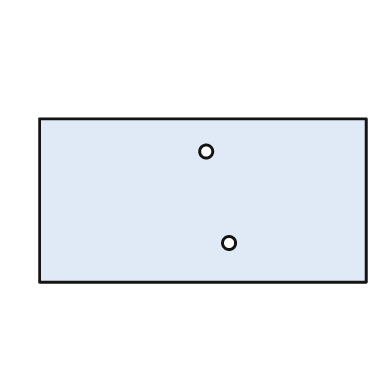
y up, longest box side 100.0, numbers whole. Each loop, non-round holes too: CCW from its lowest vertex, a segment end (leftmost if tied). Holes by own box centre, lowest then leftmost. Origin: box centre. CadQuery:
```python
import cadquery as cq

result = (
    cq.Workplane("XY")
    .moveTo(-50.0, -25.0)
    .lineTo(50.0, -25.0)
    .lineTo(50.0, 25.0)
    .lineTo(-50.0, 25.0)
    .close()
    .moveTo(8.0, -13.0)
    .circle(2.0)
    .moveTo(1.0, 15.0)
    .circle(2.0)
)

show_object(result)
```